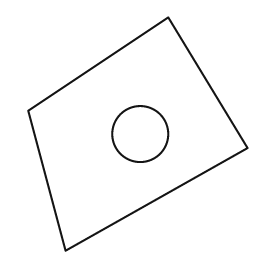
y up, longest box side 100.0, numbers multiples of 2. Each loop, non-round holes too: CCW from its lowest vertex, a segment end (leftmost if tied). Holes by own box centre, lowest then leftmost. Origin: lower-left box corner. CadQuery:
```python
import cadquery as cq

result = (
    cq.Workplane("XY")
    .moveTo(16.0, 0.0)
    .lineTo(94.0, 44.0)
    .lineTo(60.0, 100.0)
    .lineTo(0.0, 60.0)
    .close()
    .moveTo(48.0, 50.0)
    .circle(12.0)
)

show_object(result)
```